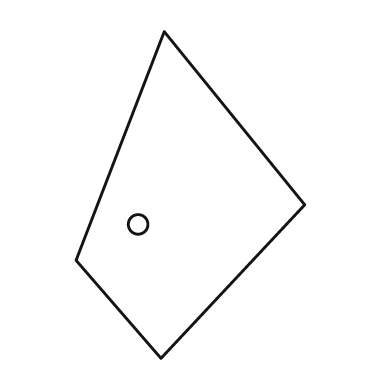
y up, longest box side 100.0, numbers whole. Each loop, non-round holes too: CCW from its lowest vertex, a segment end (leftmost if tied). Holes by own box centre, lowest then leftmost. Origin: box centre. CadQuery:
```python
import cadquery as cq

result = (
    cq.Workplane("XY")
    .moveTo(-9.0, -50.0)
    .lineTo(35.0, -3.0)
    .lineTo(-8.0, 50.0)
    .lineTo(-35.0, -20.0)
    .close()
    .moveTo(-16.0, -9.0)
    .circle(3.0)
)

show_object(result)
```